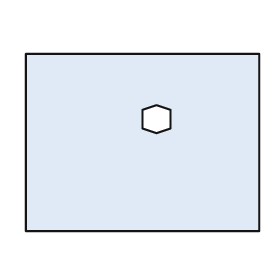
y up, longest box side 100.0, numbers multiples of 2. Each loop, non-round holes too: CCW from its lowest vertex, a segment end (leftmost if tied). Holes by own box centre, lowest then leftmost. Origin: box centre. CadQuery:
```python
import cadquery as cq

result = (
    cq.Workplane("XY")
    .moveTo(-50.0, -38.0)
    .lineTo(50.0, -38.0)
    .lineTo(50.0, 38.0)
    .lineTo(-50.0, 38.0)
    .close()
    .moveTo(6.0, 4.0)
    .lineTo(12.0, 6.0)
    .lineTo(12.0, 14.0)
    .lineTo(6.0, 16.0)
    .lineTo(0.0, 14.0)
    .lineTo(0.0, 6.0)
    .close()
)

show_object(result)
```